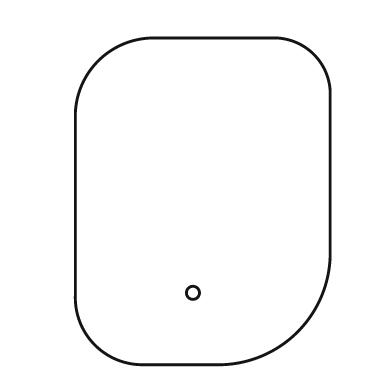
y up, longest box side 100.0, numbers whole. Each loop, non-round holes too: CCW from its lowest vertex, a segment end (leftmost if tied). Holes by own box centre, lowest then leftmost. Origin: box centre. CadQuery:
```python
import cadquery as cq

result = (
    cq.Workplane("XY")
    .moveTo(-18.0, -50.0)
    .lineTo(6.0, -50.0)
    .threePointArc((29.0, -40.0), (39.0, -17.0))
    .lineTo(39.0, 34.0)
    .threePointArc((34.0, 45.0), (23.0, 50.0))
    .lineTo(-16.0, 50.0)
    .threePointArc((-32.0, 43.0), (-39.0, 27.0))
    .lineTo(-39.0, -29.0)
    .threePointArc((-33.0, -44.0), (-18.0, -50.0))
    .close()
    .moveTo(-3.0, -28.0)
    .circle(2.0)
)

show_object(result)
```